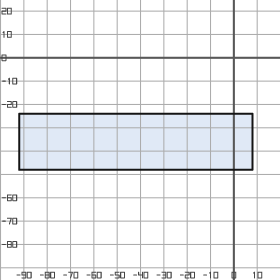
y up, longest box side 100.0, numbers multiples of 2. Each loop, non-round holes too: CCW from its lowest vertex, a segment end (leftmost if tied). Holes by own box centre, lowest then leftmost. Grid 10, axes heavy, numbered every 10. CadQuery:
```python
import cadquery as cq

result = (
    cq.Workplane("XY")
    .moveTo(-92.0, -48.0)
    .lineTo(8.0, -48.0)
    .lineTo(8.0, -24.0)
    .lineTo(-92.0, -24.0)
    .close()
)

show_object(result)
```